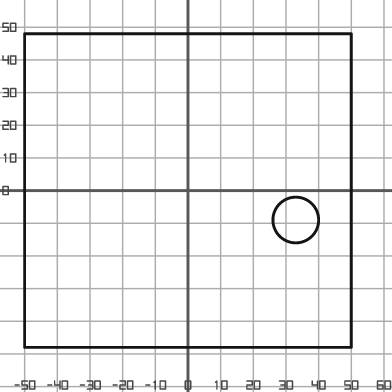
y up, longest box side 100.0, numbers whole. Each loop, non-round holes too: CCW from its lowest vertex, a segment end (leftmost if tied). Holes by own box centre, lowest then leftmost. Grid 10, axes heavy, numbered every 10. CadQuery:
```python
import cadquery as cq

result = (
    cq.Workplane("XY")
    .moveTo(-50.0, -48.0)
    .lineTo(50.0, -48.0)
    .lineTo(50.0, 48.0)
    .lineTo(-50.0, 48.0)
    .close()
    .moveTo(33.0, -9.0)
    .circle(7.0)
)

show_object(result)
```